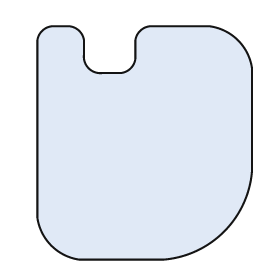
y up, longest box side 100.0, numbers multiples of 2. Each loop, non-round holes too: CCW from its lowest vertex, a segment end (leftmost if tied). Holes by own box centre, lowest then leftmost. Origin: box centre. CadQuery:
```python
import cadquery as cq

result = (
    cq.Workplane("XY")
    .moveTo(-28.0, -50.0)
    .lineTo(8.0, -50.0)
    .threePointArc((34.0, -38.0), (46.0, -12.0))
    .lineTo(46.0, 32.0)
    .threePointArc((40.0, 44.0), (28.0, 50.0))
    .lineTo(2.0, 50.0)
    .threePointArc((-2.0, 48.0), (-4.0, 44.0))
    .lineTo(-4.0, 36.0)
    .threePointArc((-6.0, 32.0), (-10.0, 30.0))
    .lineTo(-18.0, 30.0)
    .threePointArc((-24.0, 32.0), (-26.0, 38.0))
    .lineTo(-26.0, 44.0)
    .threePointArc((-28.0, 48.0), (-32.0, 50.0))
    .lineTo(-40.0, 50.0)
    .threePointArc((-44.0, 48.0), (-46.0, 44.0))
    .lineTo(-46.0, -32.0)
    .threePointArc((-40.0, -44.0), (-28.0, -50.0))
    .close()
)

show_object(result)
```